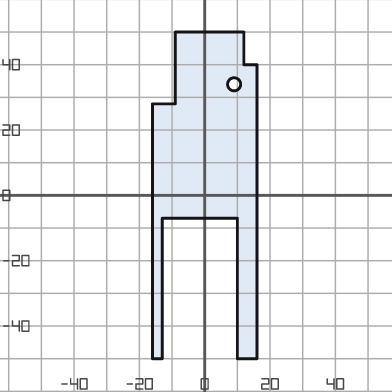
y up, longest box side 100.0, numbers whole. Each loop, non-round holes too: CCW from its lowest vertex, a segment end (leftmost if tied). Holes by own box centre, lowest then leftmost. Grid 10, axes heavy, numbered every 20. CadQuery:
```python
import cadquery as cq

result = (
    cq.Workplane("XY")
    .moveTo(-16.0, -50.0)
    .lineTo(-13.0, -50.0)
    .lineTo(-13.0, -7.0)
    .lineTo(10.0, -7.0)
    .lineTo(10.0, -50.0)
    .lineTo(16.0, -50.0)
    .lineTo(16.0, 40.0)
    .lineTo(12.0, 40.0)
    .lineTo(12.0, 50.0)
    .lineTo(-9.0, 50.0)
    .lineTo(-9.0, 28.0)
    .lineTo(-16.0, 28.0)
    .close()
    .moveTo(9.0, 34.0)
    .circle(2.0)
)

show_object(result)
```